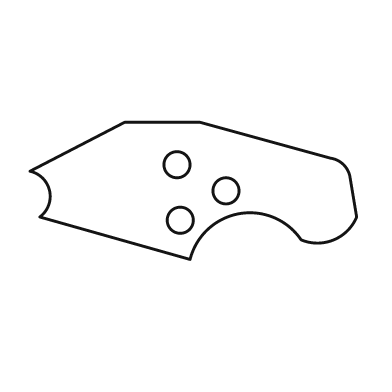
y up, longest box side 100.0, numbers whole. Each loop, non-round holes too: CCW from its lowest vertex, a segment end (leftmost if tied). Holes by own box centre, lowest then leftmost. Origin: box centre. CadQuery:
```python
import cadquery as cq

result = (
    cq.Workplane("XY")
    .moveTo(-1.0, -21.0)
    .threePointArc((14.0, -7.0), (33.0, -15.0))
    .threePointArc((43.0, -15.0), (50.0, -8.0))
    .lineTo(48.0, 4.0)
    .threePointArc((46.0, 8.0), (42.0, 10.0))
    .lineTo(2.0, 21.0)
    .lineTo(-21.0, 21.0)
    .lineTo(-50.0, 6.0)
    .threePointArc((-44.0, 0.0), (-47.0, -8.0))
    .close()
    .moveTo(-4.0, -9.0)
    .circle(4.0)
    .moveTo(10.0, 0.0)
    .circle(4.0)
    .moveTo(-5.0, 8.0)
    .circle(4.0)
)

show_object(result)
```